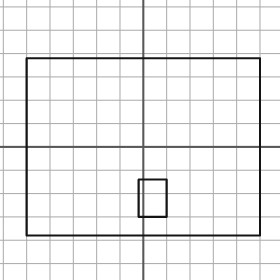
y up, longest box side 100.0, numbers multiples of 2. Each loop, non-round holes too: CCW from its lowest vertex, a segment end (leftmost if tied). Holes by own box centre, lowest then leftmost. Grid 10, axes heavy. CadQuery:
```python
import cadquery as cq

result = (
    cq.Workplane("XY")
    .moveTo(-50.0, -38.0)
    .lineTo(50.0, -38.0)
    .lineTo(50.0, 38.0)
    .lineTo(-50.0, 38.0)
    .close()
    .moveTo(-2.0, -30.0)
    .lineTo(10.0, -30.0)
    .lineTo(10.0, -14.0)
    .lineTo(-2.0, -14.0)
    .close()
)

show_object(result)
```